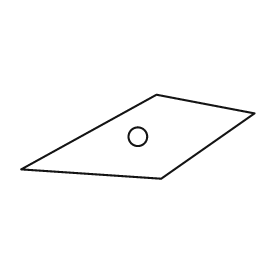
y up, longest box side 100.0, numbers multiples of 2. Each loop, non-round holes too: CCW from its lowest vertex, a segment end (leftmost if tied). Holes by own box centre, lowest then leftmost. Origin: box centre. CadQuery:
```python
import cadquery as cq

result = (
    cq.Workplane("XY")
    .moveTo(10.0, -18.0)
    .lineTo(50.0, 10.0)
    .lineTo(8.0, 18.0)
    .lineTo(-50.0, -14.0)
    .close()
    .moveTo(0.0, 0.0)
    .circle(4.0)
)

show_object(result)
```